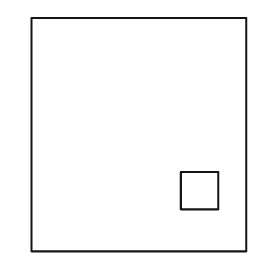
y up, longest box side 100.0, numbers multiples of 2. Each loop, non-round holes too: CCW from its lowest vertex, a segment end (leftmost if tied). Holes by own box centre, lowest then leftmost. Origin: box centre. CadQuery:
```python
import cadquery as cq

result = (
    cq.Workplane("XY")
    .moveTo(-46.0, -50.0)
    .lineTo(46.0, -50.0)
    .lineTo(46.0, 50.0)
    .lineTo(-46.0, 50.0)
    .close()
    .moveTo(18.0, -32.0)
    .lineTo(34.0, -32.0)
    .lineTo(34.0, -16.0)
    .lineTo(18.0, -16.0)
    .close()
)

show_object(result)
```